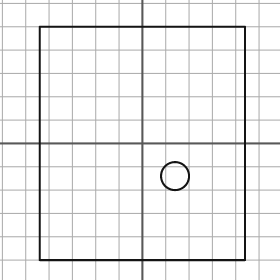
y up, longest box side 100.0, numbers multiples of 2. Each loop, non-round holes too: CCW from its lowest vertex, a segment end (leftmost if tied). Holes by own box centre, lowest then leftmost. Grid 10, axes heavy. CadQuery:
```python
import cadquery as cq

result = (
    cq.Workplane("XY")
    .moveTo(-44.0, -50.0)
    .lineTo(44.0, -50.0)
    .lineTo(44.0, 50.0)
    .lineTo(-44.0, 50.0)
    .close()
    .moveTo(14.0, -14.0)
    .circle(6.0)
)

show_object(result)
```